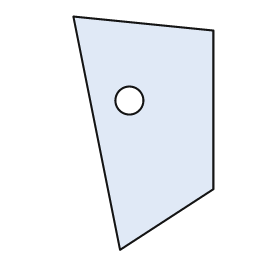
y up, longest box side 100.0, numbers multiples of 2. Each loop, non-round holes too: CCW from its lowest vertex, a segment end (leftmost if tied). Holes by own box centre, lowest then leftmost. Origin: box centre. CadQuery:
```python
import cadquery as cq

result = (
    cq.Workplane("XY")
    .moveTo(-10.0, -50.0)
    .lineTo(30.0, -24.0)
    .lineTo(30.0, 44.0)
    .lineTo(-30.0, 50.0)
    .close()
    .moveTo(-6.0, 14.0)
    .circle(6.0)
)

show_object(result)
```